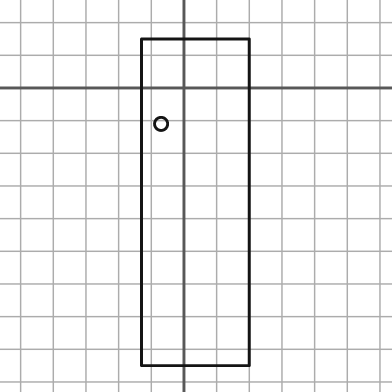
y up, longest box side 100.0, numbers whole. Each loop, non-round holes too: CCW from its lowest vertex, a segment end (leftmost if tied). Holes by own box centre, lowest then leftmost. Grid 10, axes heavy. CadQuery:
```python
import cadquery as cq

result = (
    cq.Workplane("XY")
    .moveTo(-13.0, -85.0)
    .lineTo(20.0, -85.0)
    .lineTo(20.0, 15.0)
    .lineTo(-13.0, 15.0)
    .close()
    .moveTo(-7.0, -11.0)
    .circle(2.0)
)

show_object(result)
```